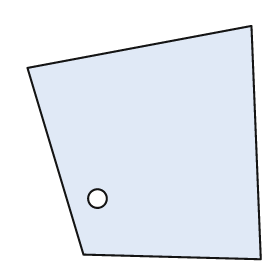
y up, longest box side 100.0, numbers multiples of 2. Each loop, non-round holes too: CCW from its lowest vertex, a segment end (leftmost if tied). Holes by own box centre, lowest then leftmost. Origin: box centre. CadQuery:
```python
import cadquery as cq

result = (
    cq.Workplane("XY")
    .moveTo(50.0, -50.0)
    .lineTo(46.0, 50.0)
    .lineTo(-50.0, 32.0)
    .lineTo(-26.0, -48.0)
    .close()
    .moveTo(-20.0, -24.0)
    .circle(4.0)
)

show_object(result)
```